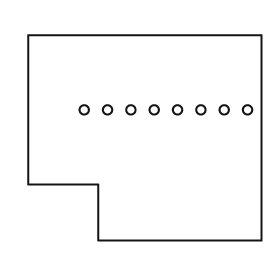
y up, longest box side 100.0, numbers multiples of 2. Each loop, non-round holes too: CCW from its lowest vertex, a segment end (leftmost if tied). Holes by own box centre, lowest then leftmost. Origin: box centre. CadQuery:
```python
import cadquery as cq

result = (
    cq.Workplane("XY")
    .moveTo(-20.0, -44.0)
    .lineTo(50.0, -44.0)
    .lineTo(50.0, 44.0)
    .lineTo(-50.0, 44.0)
    .lineTo(-50.0, -20.0)
    .lineTo(-20.0, -20.0)
    .close()
    .moveTo(-26.0, 12.0)
    .circle(2.0)
    .moveTo(-16.0, 12.0)
    .circle(2.0)
    .moveTo(-6.0, 12.0)
    .circle(2.0)
    .moveTo(4.0, 12.0)
    .circle(2.0)
    .moveTo(14.0, 12.0)
    .circle(2.0)
    .moveTo(24.0, 12.0)
    .circle(2.0)
    .moveTo(34.0, 12.0)
    .circle(2.0)
    .moveTo(44.0, 12.0)
    .circle(2.0)
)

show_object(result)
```